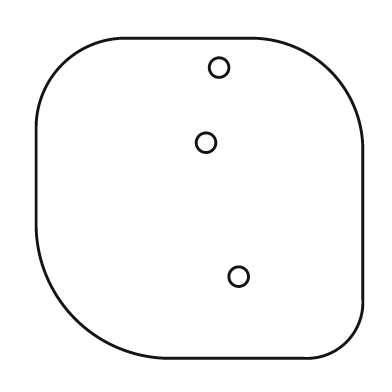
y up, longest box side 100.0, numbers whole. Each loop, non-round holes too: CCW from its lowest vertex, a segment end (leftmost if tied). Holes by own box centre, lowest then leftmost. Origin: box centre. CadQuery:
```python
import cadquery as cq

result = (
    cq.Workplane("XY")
    .moveTo(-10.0, -49.0)
    .lineTo(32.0, -49.0)
    .threePointArc((45.0, -44.0), (50.0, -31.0))
    .lineTo(50.0, 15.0)
    .threePointArc((40.0, 39.0), (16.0, 49.0))
    .lineTo(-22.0, 49.0)
    .threePointArc((-42.0, 41.0), (-50.0, 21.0))
    .lineTo(-50.0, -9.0)
    .threePointArc((-38.0, -37.0), (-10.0, -49.0))
    .close()
    .moveTo(12.0, -24.0)
    .circle(3.0)
    .moveTo(2.0, 17.0)
    .circle(3.0)
    .moveTo(6.0, 40.0)
    .circle(3.0)
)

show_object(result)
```